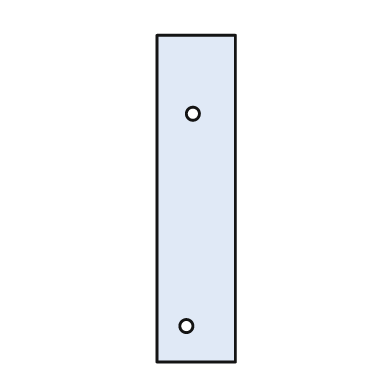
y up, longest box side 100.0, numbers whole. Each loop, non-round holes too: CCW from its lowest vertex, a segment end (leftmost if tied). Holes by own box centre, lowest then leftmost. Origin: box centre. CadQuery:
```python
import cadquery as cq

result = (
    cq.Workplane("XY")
    .moveTo(-12.0, -50.0)
    .lineTo(12.0, -50.0)
    .lineTo(12.0, 50.0)
    .lineTo(-12.0, 50.0)
    .close()
    .moveTo(-3.0, -39.0)
    .circle(2.0)
    .moveTo(-1.0, 26.0)
    .circle(2.0)
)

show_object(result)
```